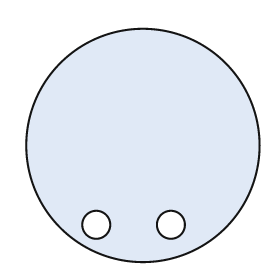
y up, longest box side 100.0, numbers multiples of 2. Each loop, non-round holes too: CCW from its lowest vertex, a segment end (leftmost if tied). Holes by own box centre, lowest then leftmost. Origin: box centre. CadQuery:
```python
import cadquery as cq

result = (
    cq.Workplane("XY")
    .moveTo(0.0, 0.0)
    .circle(50.0)
    .moveTo(-20.0, -34.0)
    .circle(6.0)
    .moveTo(12.0, -34.0)
    .circle(6.0)
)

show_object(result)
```